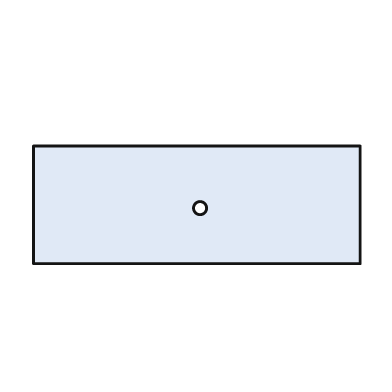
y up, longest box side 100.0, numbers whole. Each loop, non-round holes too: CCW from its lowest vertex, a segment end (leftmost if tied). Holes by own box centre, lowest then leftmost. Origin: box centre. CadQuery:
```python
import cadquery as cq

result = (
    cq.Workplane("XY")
    .moveTo(-50.0, -18.0)
    .lineTo(50.0, -18.0)
    .lineTo(50.0, 18.0)
    .lineTo(-50.0, 18.0)
    .close()
    .moveTo(1.0, -1.0)
    .circle(2.0)
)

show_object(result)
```